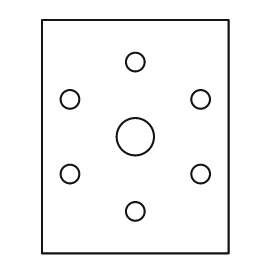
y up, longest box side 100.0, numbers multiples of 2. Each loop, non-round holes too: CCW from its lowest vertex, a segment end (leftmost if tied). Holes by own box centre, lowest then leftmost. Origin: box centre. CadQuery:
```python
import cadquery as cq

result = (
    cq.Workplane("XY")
    .moveTo(-40.0, -50.0)
    .lineTo(40.0, -50.0)
    .lineTo(40.0, 50.0)
    .lineTo(-40.0, 50.0)
    .close()
    .moveTo(0.0, -32.0)
    .circle(4.0)
    .moveTo(-28.0, -16.0)
    .circle(4.0)
    .moveTo(28.0, -16.0)
    .circle(4.0)
    .moveTo(0.0, 0.0)
    .circle(8.0)
    .moveTo(-28.0, 16.0)
    .circle(4.0)
    .moveTo(28.0, 16.0)
    .circle(4.0)
    .moveTo(0.0, 32.0)
    .circle(4.0)
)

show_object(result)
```